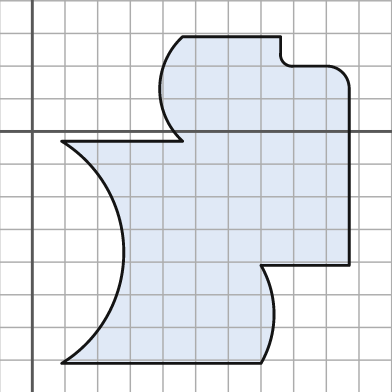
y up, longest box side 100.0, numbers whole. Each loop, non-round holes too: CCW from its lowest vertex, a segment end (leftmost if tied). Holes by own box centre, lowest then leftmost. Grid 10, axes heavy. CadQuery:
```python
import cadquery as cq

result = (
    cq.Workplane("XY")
    .moveTo(9.0, -71.0)
    .lineTo(70.0, -71.0)
    .threePointArc((74.0, -56.0), (70.0, -41.0))
    .lineTo(97.0, -41.0)
    .lineTo(97.0, 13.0)
    .threePointArc((95.0, 18.0), (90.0, 20.0))
    .lineTo(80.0, 20.0)
    .threePointArc((77.0, 21.0), (76.0, 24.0))
    .lineTo(76.0, 29.0)
    .lineTo(46.0, 29.0)
    .threePointArc((39.0, 13.0), (46.0, -3.0))
    .lineTo(9.0, -3.0)
    .threePointArc((28.0, -37.0), (9.0, -71.0))
    .close()
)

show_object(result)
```